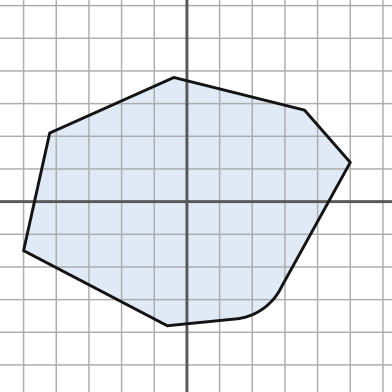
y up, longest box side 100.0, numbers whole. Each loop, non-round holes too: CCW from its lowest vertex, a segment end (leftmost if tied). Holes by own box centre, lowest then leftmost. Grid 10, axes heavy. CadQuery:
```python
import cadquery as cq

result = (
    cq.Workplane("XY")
    .moveTo(-6.0, -38.0)
    .lineTo(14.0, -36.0)
    .threePointArc((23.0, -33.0), (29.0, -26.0))
    .lineTo(50.0, 12.0)
    .lineTo(36.0, 28.0)
    .lineTo(-4.0, 38.0)
    .lineTo(-42.0, 21.0)
    .lineTo(-50.0, -15.0)
    .close()
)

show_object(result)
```